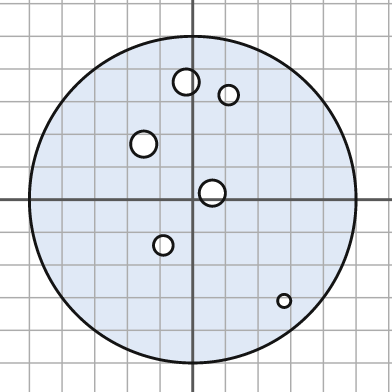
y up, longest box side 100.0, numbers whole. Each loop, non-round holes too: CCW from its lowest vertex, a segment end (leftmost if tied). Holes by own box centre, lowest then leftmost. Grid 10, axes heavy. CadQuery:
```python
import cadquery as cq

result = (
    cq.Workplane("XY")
    .moveTo(0.0, 0.0)
    .circle(50.0)
    .moveTo(28.0, -31.0)
    .circle(2.0)
    .moveTo(-9.0, -14.0)
    .circle(3.0)
    .moveTo(6.0, 2.0)
    .circle(4.0)
    .moveTo(-15.0, 17.0)
    .circle(4.0)
    .moveTo(11.0, 32.0)
    .circle(3.0)
    .moveTo(-2.0, 36.0)
    .circle(4.0)
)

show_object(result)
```